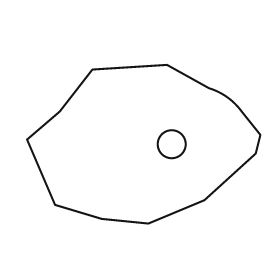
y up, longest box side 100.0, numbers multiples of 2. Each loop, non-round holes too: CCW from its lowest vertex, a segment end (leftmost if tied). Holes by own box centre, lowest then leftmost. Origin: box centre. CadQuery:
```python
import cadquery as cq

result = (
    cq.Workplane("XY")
    .moveTo(2.0, -34.0)
    .lineTo(26.0, -24.0)
    .lineTo(48.0, -4.0)
    .lineTo(50.0, 4.0)
    .lineTo(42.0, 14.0)
    .threePointArc((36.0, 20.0), (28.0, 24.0))
    .lineTo(10.0, 34.0)
    .lineTo(-22.0, 32.0)
    .lineTo(-36.0, 14.0)
    .lineTo(-50.0, 2.0)
    .lineTo(-38.0, -26.0)
    .lineTo(-18.0, -32.0)
    .close()
    .moveTo(12.0, 0.0)
    .circle(6.0)
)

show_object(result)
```